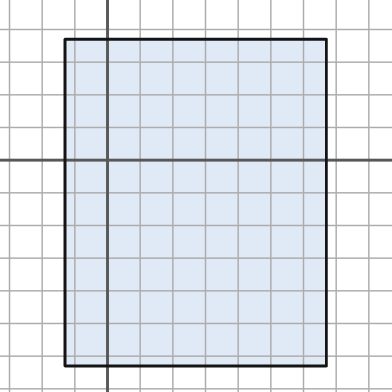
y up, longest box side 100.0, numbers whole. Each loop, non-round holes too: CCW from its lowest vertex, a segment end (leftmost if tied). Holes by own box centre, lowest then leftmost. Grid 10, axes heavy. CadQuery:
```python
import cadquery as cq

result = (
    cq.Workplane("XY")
    .moveTo(-13.0, -63.0)
    .lineTo(67.0, -63.0)
    .lineTo(67.0, 37.0)
    .lineTo(-13.0, 37.0)
    .close()
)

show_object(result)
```